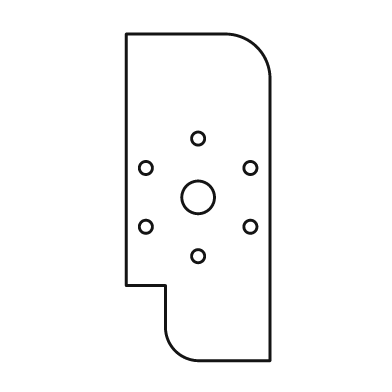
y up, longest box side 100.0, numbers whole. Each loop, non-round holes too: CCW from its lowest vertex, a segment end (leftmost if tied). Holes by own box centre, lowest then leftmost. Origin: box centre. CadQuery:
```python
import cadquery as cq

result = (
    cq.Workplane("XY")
    .moveTo(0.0, -50.0)
    .lineTo(22.0, -50.0)
    .lineTo(22.0, 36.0)
    .threePointArc((18.0, 46.0), (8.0, 50.0))
    .lineTo(-22.0, 50.0)
    .lineTo(-22.0, -27.0)
    .lineTo(-10.0, -27.0)
    .lineTo(-10.0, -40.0)
    .threePointArc((-7.0, -47.0), (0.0, -50.0))
    .close()
    .moveTo(0.0, -18.0)
    .circle(2.0)
    .moveTo(-16.0, -9.0)
    .circle(2.0)
    .moveTo(16.0, -9.0)
    .circle(2.0)
    .moveTo(0.0, 0.0)
    .circle(5.0)
    .moveTo(-16.0, 9.0)
    .circle(2.0)
    .moveTo(16.0, 9.0)
    .circle(2.0)
    .moveTo(0.0, 18.0)
    .circle(2.0)
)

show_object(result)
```